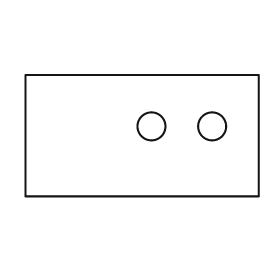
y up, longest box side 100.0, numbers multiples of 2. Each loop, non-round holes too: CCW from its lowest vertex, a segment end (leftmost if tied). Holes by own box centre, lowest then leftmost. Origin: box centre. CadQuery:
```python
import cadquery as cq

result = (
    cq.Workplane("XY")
    .moveTo(-50.0, -26.0)
    .lineTo(50.0, -26.0)
    .lineTo(50.0, 26.0)
    .lineTo(-50.0, 26.0)
    .close()
    .moveTo(4.0, 4.0)
    .circle(6.0)
    .moveTo(30.0, 4.0)
    .circle(6.0)
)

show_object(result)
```